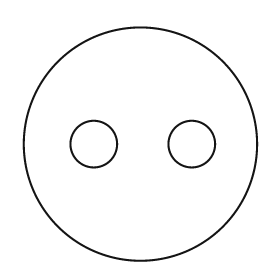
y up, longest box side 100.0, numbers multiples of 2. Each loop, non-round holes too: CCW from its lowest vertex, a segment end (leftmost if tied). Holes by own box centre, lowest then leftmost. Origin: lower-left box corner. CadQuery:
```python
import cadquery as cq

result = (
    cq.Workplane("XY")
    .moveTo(50.0, 50.0)
    .circle(50.0)
    .moveTo(30.0, 50.0)
    .circle(10.0)
    .moveTo(72.0, 50.0)
    .circle(10.0)
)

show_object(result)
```